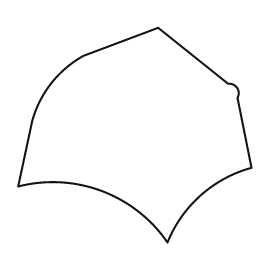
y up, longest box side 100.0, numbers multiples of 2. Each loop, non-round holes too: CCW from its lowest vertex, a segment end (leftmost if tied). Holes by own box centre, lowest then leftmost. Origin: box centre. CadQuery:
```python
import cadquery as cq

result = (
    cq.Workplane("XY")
    .moveTo(14.0, -46.0)
    .threePointArc((28.0, -26.0), (50.0, -14.0))
    .lineTo(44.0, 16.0)
    .threePointArc((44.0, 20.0), (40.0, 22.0))
    .lineTo(10.0, 46.0)
    .lineTo(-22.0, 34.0)
    .threePointArc((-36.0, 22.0), (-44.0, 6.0))
    .lineTo(-50.0, -22.0)
    .threePointArc((-14.0, -24.0), (14.0, -46.0))
    .close()
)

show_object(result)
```